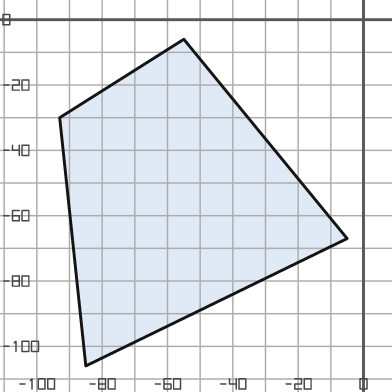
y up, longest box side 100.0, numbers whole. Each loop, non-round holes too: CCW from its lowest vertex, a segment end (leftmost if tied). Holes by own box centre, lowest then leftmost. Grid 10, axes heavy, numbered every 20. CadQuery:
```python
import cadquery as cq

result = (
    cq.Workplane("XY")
    .moveTo(-85.0, -106.0)
    .lineTo(-5.0, -67.0)
    .lineTo(-55.0, -6.0)
    .lineTo(-93.0, -30.0)
    .close()
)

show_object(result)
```